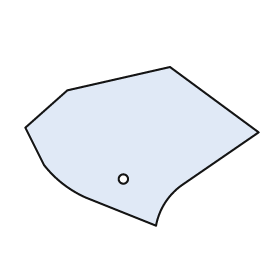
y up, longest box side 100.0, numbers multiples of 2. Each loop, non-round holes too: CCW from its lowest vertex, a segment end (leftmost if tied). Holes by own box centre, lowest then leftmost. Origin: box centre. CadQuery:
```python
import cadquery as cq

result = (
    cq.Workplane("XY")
    .moveTo(6.0, -34.0)
    .threePointArc((10.0, -24.0), (18.0, -16.0))
    .lineTo(50.0, 6.0)
    .lineTo(12.0, 34.0)
    .lineTo(-32.0, 24.0)
    .lineTo(-50.0, 8.0)
    .lineTo(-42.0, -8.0)
    .threePointArc((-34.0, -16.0), (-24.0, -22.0))
    .close()
    .moveTo(-8.0, -14.0)
    .circle(2.0)
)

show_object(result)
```